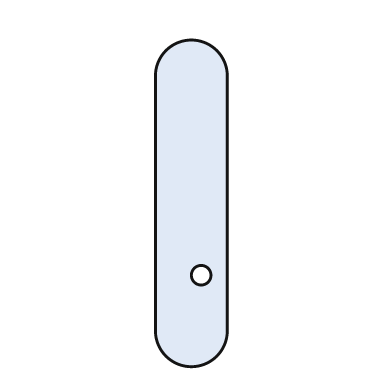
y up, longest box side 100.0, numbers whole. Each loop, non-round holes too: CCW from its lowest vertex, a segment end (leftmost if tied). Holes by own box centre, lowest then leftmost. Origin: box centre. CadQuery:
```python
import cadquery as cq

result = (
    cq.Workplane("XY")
    .moveTo(-11.0, -39.0)
    .threePointArc((0.0, -50.0), (11.0, -39.0))
    .lineTo(11.0, 39.0)
    .threePointArc((0.0, 50.0), (-11.0, 39.0))
    .close()
    .moveTo(3.0, -22.0)
    .circle(3.0)
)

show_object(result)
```